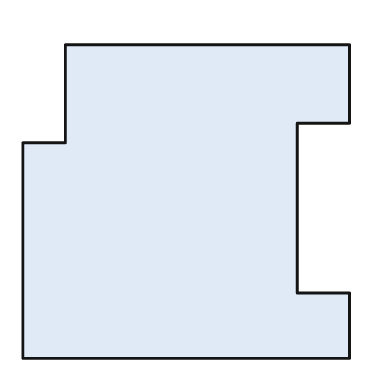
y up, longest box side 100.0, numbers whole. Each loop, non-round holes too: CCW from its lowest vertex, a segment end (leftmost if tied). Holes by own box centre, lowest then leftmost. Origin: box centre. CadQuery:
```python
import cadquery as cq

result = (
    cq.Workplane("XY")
    .moveTo(-50.0, -48.0)
    .lineTo(50.0, -48.0)
    .lineTo(50.0, -28.0)
    .lineTo(34.0, -28.0)
    .lineTo(34.0, 24.0)
    .lineTo(50.0, 24.0)
    .lineTo(50.0, 48.0)
    .lineTo(-37.0, 48.0)
    .lineTo(-37.0, 18.0)
    .lineTo(-50.0, 18.0)
    .close()
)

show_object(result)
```